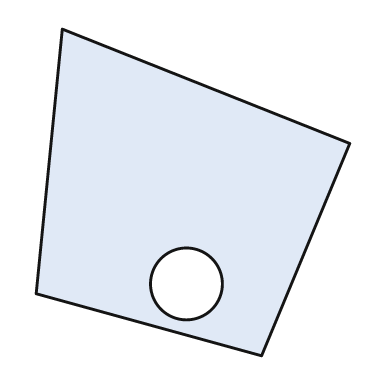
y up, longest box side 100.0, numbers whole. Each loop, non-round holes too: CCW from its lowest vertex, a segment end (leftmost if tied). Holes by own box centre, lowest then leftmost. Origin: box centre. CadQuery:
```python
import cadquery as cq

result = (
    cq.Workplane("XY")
    .moveTo(21.0, -50.0)
    .lineTo(48.0, 15.0)
    .lineTo(-40.0, 50.0)
    .lineTo(-48.0, -31.0)
    .close()
    .moveTo(-2.0, -28.0)
    .circle(11.0)
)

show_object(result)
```